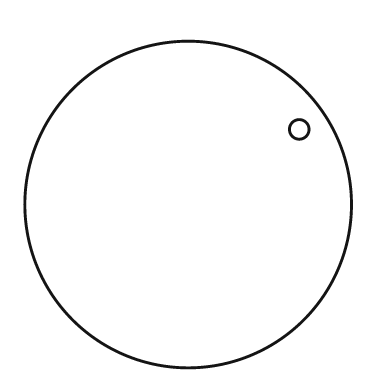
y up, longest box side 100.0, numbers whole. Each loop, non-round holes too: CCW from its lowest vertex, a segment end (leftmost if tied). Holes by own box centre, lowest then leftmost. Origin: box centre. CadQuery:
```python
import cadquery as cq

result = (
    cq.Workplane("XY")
    .moveTo(0.0, 0.0)
    .circle(50.0)
    .moveTo(34.0, 23.0)
    .circle(3.0)
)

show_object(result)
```